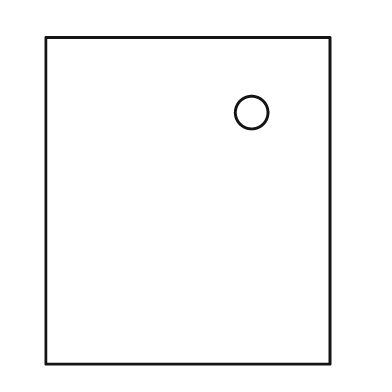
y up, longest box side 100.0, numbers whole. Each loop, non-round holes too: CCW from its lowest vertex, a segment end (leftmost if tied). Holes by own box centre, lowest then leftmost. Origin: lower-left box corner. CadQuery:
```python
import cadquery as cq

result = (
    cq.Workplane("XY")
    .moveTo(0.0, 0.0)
    .lineTo(87.0, 0.0)
    .lineTo(87.0, 100.0)
    .lineTo(0.0, 100.0)
    .close()
    .moveTo(63.0, 77.0)
    .circle(5.0)
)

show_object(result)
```